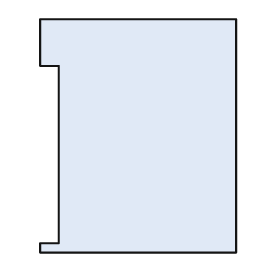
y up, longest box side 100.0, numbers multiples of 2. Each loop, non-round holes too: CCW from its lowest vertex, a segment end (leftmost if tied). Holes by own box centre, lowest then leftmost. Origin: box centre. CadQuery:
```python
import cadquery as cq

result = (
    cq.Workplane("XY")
    .moveTo(-42.0, -50.0)
    .lineTo(42.0, -50.0)
    .lineTo(42.0, 50.0)
    .lineTo(-42.0, 50.0)
    .lineTo(-42.0, 30.0)
    .lineTo(-34.0, 30.0)
    .lineTo(-34.0, -46.0)
    .lineTo(-42.0, -46.0)
    .close()
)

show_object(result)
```